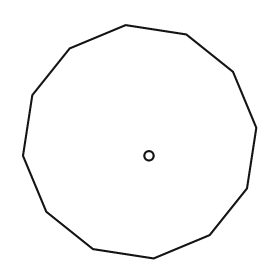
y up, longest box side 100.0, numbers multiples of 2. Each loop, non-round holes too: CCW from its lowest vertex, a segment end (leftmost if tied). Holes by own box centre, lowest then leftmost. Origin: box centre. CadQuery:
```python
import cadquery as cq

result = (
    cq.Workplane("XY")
    .moveTo(6.0, -50.0)
    .lineTo(30.0, -40.0)
    .lineTo(46.0, -20.0)
    .lineTo(50.0, 6.0)
    .lineTo(40.0, 30.0)
    .lineTo(20.0, 46.0)
    .lineTo(-6.0, 50.0)
    .lineTo(-30.0, 40.0)
    .lineTo(-46.0, 20.0)
    .lineTo(-50.0, -6.0)
    .lineTo(-40.0, -30.0)
    .lineTo(-20.0, -46.0)
    .close()
    .moveTo(4.0, -6.0)
    .circle(2.0)
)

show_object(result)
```